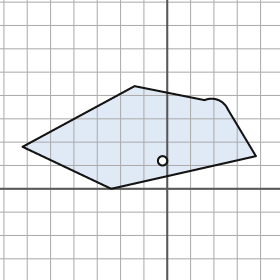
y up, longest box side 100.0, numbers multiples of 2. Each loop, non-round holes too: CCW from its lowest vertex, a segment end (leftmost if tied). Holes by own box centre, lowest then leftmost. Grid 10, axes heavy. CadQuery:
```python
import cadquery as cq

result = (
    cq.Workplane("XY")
    .moveTo(-24.0, 0.0)
    .lineTo(38.0, 14.0)
    .lineTo(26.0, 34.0)
    .threePointArc((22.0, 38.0), (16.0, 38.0))
    .lineTo(-14.0, 44.0)
    .lineTo(-62.0, 18.0)
    .close()
    .moveTo(-2.0, 12.0)
    .circle(2.0)
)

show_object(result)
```